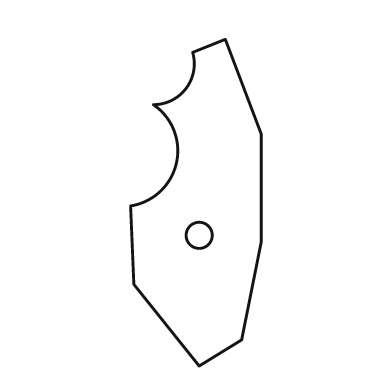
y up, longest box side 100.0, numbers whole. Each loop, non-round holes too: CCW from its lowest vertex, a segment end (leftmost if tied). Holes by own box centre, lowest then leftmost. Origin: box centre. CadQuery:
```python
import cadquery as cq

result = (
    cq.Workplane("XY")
    .moveTo(1.0, -50.0)
    .lineTo(14.0, -42.0)
    .lineTo(20.0, -12.0)
    .lineTo(20.0, 21.0)
    .lineTo(9.0, 50.0)
    .lineTo(-1.0, 46.0)
    .threePointArc((-3.0, 35.0), (-13.0, 30.0))
    .threePointArc((-6.0, 12.0), (-20.0, -1.0))
    .lineTo(-19.0, -25.0)
    .close()
    .moveTo(1.0, -10.0)
    .circle(4.0)
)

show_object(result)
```